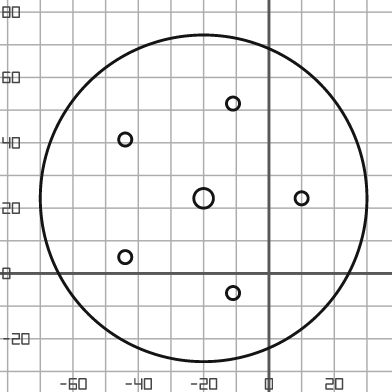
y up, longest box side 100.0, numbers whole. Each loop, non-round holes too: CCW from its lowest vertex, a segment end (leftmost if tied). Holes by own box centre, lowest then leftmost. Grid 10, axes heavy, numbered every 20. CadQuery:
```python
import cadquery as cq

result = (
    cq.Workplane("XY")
    .moveTo(-20.0, 23.0)
    .circle(50.0)
    .moveTo(-11.0, -6.0)
    .circle(2.0)
    .moveTo(-44.0, 5.0)
    .circle(2.0)
    .moveTo(-20.0, 23.0)
    .circle(3.0)
    .moveTo(10.0, 23.0)
    .circle(2.0)
    .moveTo(-44.0, 41.0)
    .circle(2.0)
    .moveTo(-11.0, 52.0)
    .circle(2.0)
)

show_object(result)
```